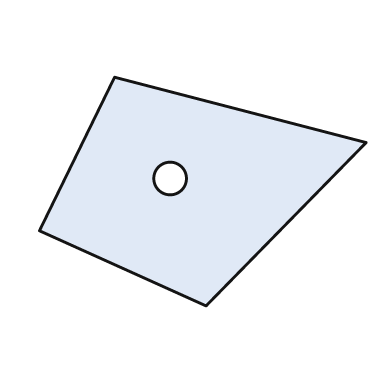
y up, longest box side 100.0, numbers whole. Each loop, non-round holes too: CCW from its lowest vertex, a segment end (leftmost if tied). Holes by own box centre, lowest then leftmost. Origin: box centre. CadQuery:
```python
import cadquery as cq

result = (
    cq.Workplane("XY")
    .moveTo(1.0, -35.0)
    .lineTo(50.0, 15.0)
    .lineTo(-27.0, 35.0)
    .lineTo(-50.0, -12.0)
    .close()
    .moveTo(-10.0, 4.0)
    .circle(5.0)
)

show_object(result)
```